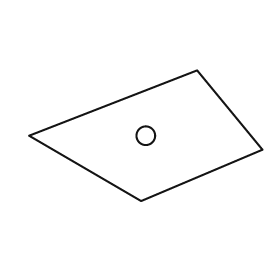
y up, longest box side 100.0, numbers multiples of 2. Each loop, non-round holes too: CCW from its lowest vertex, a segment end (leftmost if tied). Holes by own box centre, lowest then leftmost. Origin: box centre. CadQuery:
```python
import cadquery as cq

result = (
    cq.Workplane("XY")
    .moveTo(-2.0, -28.0)
    .lineTo(50.0, -6.0)
    .lineTo(22.0, 28.0)
    .lineTo(-50.0, 0.0)
    .close()
    .moveTo(0.0, 0.0)
    .circle(4.0)
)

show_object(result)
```